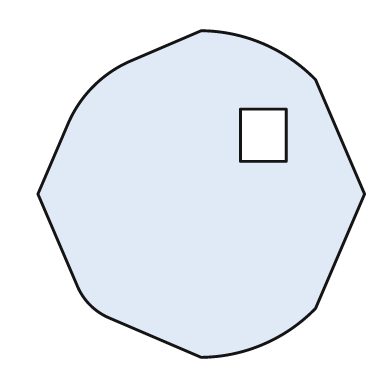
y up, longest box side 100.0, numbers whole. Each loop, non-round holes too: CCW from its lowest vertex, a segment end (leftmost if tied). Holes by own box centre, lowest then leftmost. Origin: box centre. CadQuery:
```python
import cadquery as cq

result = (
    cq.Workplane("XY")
    .moveTo(0.0, -50.0)
    .threePointArc((19.0, -46.0), (35.0, -35.0))
    .lineTo(50.0, 0.0)
    .lineTo(35.0, 35.0)
    .threePointArc((19.0, 46.0), (0.0, 50.0))
    .lineTo(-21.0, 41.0)
    .threePointArc((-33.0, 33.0), (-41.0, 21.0))
    .lineTo(-50.0, 0.0)
    .lineTo(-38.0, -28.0)
    .threePointArc((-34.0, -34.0), (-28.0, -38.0))
    .close()
    .moveTo(12.0, 10.0)
    .lineTo(26.0, 10.0)
    .lineTo(26.0, 26.0)
    .lineTo(12.0, 26.0)
    .close()
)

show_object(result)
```